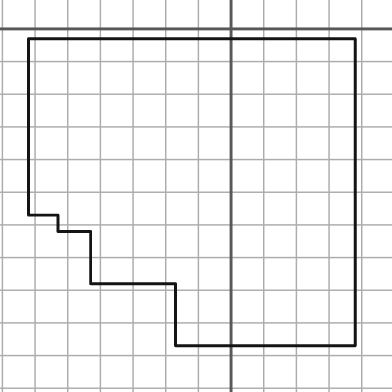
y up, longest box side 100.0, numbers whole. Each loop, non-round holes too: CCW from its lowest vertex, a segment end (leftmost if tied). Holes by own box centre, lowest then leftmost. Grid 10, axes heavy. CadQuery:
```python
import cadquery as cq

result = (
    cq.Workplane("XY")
    .moveTo(-17.0, -97.0)
    .lineTo(38.0, -97.0)
    .lineTo(38.0, -3.0)
    .lineTo(-62.0, -3.0)
    .lineTo(-62.0, -57.0)
    .lineTo(-53.0, -57.0)
    .lineTo(-53.0, -62.0)
    .lineTo(-43.0, -62.0)
    .lineTo(-43.0, -78.0)
    .lineTo(-17.0, -78.0)
    .close()
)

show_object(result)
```